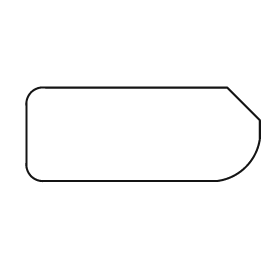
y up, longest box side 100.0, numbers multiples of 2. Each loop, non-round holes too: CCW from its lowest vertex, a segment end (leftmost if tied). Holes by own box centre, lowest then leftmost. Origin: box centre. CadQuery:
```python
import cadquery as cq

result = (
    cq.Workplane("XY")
    .moveTo(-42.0, -20.0)
    .lineTo(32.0, -20.0)
    .threePointArc((44.0, -14.0), (50.0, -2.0))
    .lineTo(50.0, 6.0)
    .lineTo(36.0, 20.0)
    .lineTo(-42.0, 20.0)
    .threePointArc((-48.0, 18.0), (-50.0, 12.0))
    .lineTo(-50.0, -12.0)
    .threePointArc((-48.0, -18.0), (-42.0, -20.0))
    .close()
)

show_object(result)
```